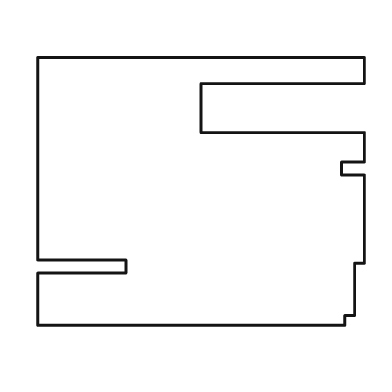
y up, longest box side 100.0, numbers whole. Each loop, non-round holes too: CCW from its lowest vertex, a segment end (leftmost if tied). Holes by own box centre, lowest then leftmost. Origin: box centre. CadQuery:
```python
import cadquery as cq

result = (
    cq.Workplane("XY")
    .moveTo(-50.0, -41.0)
    .lineTo(44.0, -41.0)
    .lineTo(44.0, -38.0)
    .lineTo(47.0, -38.0)
    .lineTo(47.0, -22.0)
    .lineTo(50.0, -22.0)
    .lineTo(50.0, 5.0)
    .lineTo(43.0, 5.0)
    .lineTo(43.0, 9.0)
    .lineTo(50.0, 9.0)
    .lineTo(50.0, 18.0)
    .lineTo(0.0, 18.0)
    .lineTo(0.0, 33.0)
    .lineTo(50.0, 33.0)
    .lineTo(50.0, 41.0)
    .lineTo(-50.0, 41.0)
    .lineTo(-50.0, -21.0)
    .lineTo(-23.0, -21.0)
    .lineTo(-23.0, -25.0)
    .lineTo(-50.0, -25.0)
    .close()
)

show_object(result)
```